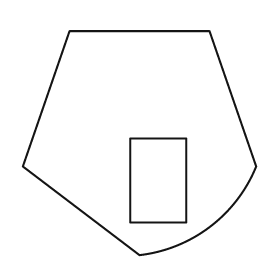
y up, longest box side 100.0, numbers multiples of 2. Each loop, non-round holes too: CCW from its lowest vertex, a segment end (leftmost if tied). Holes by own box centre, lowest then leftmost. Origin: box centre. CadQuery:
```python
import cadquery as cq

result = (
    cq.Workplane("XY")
    .moveTo(0.0, -48.0)
    .threePointArc((30.0, -36.0), (50.0, -10.0))
    .lineTo(30.0, 48.0)
    .lineTo(-30.0, 48.0)
    .lineTo(-50.0, -10.0)
    .close()
    .moveTo(-4.0, -34.0)
    .lineTo(20.0, -34.0)
    .lineTo(20.0, 2.0)
    .lineTo(-4.0, 2.0)
    .close()
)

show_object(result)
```